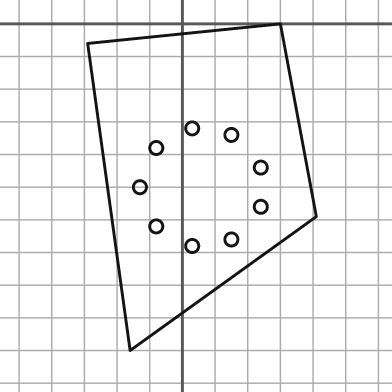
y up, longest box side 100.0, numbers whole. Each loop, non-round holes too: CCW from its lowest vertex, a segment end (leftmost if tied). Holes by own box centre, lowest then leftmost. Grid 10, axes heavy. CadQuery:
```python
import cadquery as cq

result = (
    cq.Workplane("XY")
    .moveTo(-16.0, -100.0)
    .lineTo(41.0, -59.0)
    .lineTo(30.0, 0.0)
    .lineTo(-29.0, -6.0)
    .close()
    .moveTo(3.0, -68.0)
    .circle(2.0)
    .moveTo(15.0, -66.0)
    .circle(2.0)
    .moveTo(-8.0, -62.0)
    .circle(2.0)
    .moveTo(24.0, -56.0)
    .circle(2.0)
    .moveTo(-13.0, -50.0)
    .circle(2.0)
    .moveTo(24.0, -44.0)
    .circle(2.0)
    .moveTo(-8.0, -38.0)
    .circle(2.0)
    .moveTo(15.0, -34.0)
    .circle(2.0)
    .moveTo(3.0, -32.0)
    .circle(2.0)
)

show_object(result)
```